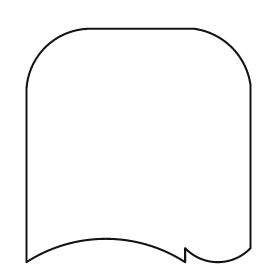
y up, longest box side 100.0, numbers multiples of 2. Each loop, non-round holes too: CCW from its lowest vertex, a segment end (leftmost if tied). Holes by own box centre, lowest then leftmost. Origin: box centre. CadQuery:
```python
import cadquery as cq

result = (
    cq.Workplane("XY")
    .moveTo(-48.0, -50.0)
    .threePointArc((-14.0, -40.0), (20.0, -50.0))
    .lineTo(20.0, -44.0)
    .threePointArc((34.0, -50.0), (48.0, -44.0))
    .lineTo(48.0, 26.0)
    .threePointArc((40.0, 42.0), (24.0, 50.0))
    .lineTo(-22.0, 50.0)
    .threePointArc((-40.0, 42.0), (-48.0, 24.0))
    .close()
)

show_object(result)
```